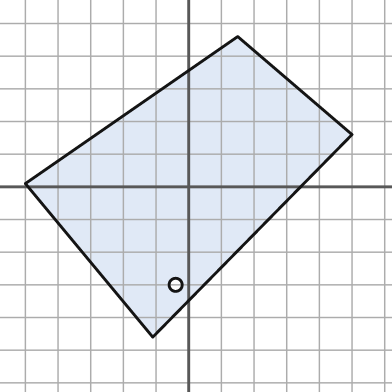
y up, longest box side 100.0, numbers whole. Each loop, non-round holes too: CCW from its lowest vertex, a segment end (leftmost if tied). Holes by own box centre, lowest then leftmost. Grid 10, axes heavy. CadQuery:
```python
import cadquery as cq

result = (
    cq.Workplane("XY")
    .moveTo(-11.0, -46.0)
    .lineTo(50.0, 16.0)
    .lineTo(15.0, 46.0)
    .lineTo(-50.0, 1.0)
    .close()
    .moveTo(-4.0, -30.0)
    .circle(2.0)
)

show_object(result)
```